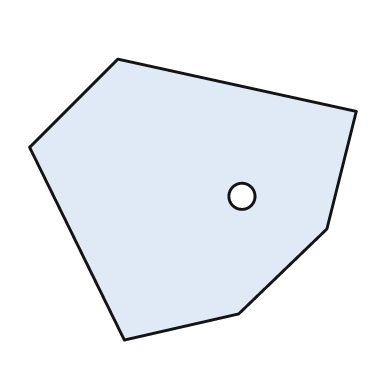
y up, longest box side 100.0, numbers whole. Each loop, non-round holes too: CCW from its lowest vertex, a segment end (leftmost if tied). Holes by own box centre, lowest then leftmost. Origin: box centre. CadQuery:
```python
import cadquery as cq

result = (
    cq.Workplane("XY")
    .moveTo(-21.0, -43.0)
    .lineTo(14.0, -35.0)
    .lineTo(41.0, -9.0)
    .lineTo(50.0, 27.0)
    .lineTo(-23.0, 43.0)
    .lineTo(-50.0, 16.0)
    .close()
    .moveTo(15.0, 1.0)
    .circle(4.0)
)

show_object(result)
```